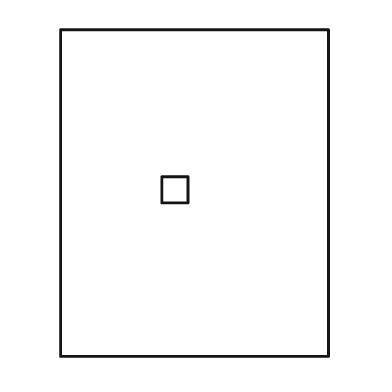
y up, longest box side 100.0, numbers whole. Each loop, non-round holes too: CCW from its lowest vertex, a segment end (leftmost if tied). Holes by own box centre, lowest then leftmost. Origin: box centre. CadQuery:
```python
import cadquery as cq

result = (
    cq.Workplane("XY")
    .moveTo(-41.0, -50.0)
    .lineTo(41.0, -50.0)
    .lineTo(41.0, 50.0)
    .lineTo(-41.0, 50.0)
    .close()
    .moveTo(-10.0, -3.0)
    .lineTo(-2.0, -3.0)
    .lineTo(-2.0, 5.0)
    .lineTo(-10.0, 5.0)
    .close()
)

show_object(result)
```